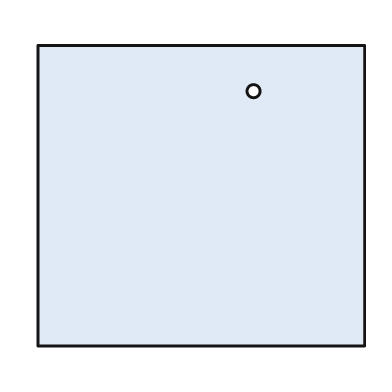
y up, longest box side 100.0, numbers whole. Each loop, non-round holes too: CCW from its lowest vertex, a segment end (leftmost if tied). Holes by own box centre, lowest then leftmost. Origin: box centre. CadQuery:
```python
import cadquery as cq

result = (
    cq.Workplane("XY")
    .moveTo(-50.0, -46.0)
    .lineTo(50.0, -46.0)
    .lineTo(50.0, 46.0)
    .lineTo(-50.0, 46.0)
    .close()
    .moveTo(16.0, 32.0)
    .circle(2.0)
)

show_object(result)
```